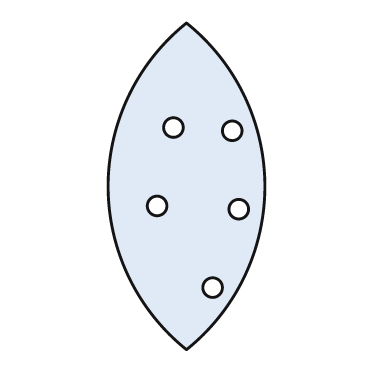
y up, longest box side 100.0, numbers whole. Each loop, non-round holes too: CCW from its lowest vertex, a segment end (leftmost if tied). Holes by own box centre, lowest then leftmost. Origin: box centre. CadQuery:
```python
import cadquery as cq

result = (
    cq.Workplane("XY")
    .moveTo(0.0, -50.0)
    .threePointArc((24.0, 0.0), (0.0, 50.0))
    .threePointArc((-24.0, 0.0), (0.0, -50.0))
    .close()
    .moveTo(8.0, -31.0)
    .circle(3.0)
    .moveTo(16.0, -7.0)
    .circle(3.0)
    .moveTo(-9.0, -6.0)
    .circle(3.0)
    .moveTo(14.0, 17.0)
    .circle(3.0)
    .moveTo(-4.0, 18.0)
    .circle(3.0)
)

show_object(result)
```